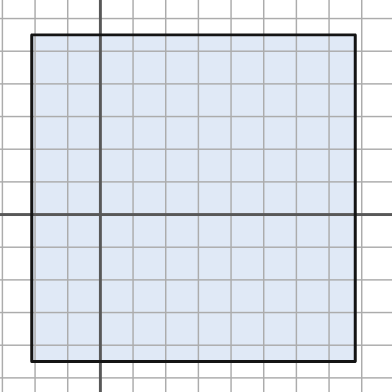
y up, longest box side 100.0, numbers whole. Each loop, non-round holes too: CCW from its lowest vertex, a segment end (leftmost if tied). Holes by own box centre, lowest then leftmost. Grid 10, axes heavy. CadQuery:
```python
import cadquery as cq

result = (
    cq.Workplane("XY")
    .moveTo(-21.0, -45.0)
    .lineTo(78.0, -45.0)
    .lineTo(78.0, 55.0)
    .lineTo(-21.0, 55.0)
    .close()
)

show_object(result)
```